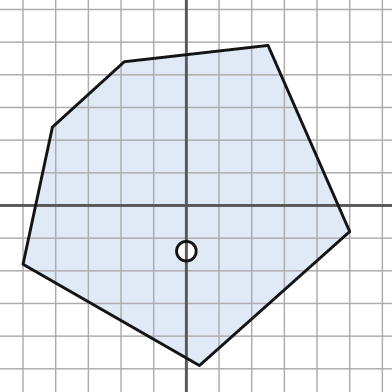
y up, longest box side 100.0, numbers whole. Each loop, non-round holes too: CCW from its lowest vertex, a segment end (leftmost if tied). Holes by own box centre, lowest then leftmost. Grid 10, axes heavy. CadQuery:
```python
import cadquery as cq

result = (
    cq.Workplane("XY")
    .moveTo(4.0, -49.0)
    .lineTo(50.0, -8.0)
    .lineTo(25.0, 49.0)
    .lineTo(-19.0, 44.0)
    .lineTo(-41.0, 24.0)
    .lineTo(-50.0, -18.0)
    .close()
    .moveTo(0.0, -14.0)
    .circle(3.0)
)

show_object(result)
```